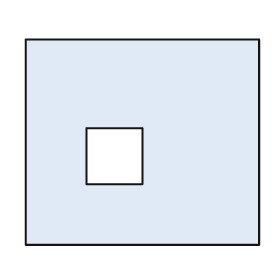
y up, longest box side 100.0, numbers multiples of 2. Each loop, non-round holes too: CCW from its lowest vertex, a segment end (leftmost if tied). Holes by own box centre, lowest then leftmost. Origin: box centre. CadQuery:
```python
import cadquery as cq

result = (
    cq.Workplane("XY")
    .moveTo(-50.0, -44.0)
    .lineTo(50.0, -44.0)
    .lineTo(50.0, 44.0)
    .lineTo(-50.0, 44.0)
    .close()
    .moveTo(-24.0, -18.0)
    .lineTo(0.0, -18.0)
    .lineTo(0.0, 6.0)
    .lineTo(-24.0, 6.0)
    .close()
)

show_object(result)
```